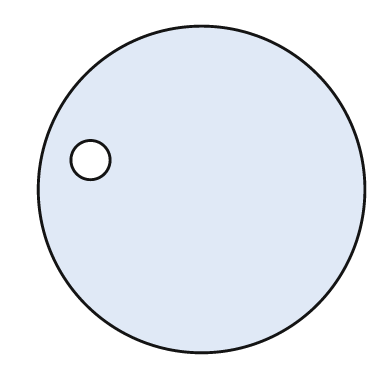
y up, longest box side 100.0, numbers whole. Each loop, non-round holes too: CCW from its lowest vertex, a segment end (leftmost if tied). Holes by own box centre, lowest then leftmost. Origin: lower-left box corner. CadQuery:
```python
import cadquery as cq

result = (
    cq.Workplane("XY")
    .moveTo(50.0, 50.0)
    .circle(50.0)
    .moveTo(16.0, 59.0)
    .circle(6.0)
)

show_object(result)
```